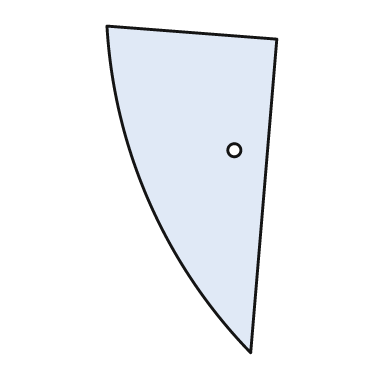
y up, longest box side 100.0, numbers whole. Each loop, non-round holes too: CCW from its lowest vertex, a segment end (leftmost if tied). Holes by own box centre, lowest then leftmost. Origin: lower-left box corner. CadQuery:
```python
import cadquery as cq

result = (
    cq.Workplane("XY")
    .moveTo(44.0, 0.0)
    .lineTo(52.0, 96.0)
    .lineTo(0.0, 100.0)
    .threePointArc((13.0, 46.0), (44.0, 0.0))
    .close()
    .moveTo(39.0, 62.0)
    .circle(2.0)
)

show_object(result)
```